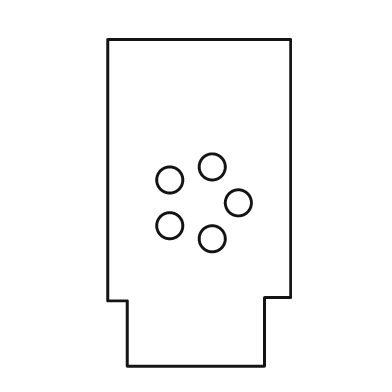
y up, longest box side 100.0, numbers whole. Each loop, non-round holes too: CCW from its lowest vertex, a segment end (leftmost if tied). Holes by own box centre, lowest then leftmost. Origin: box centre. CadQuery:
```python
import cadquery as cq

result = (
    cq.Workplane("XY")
    .moveTo(-22.0, -50.0)
    .lineTo(20.0, -50.0)
    .lineTo(20.0, -29.0)
    .lineTo(28.0, -29.0)
    .lineTo(28.0, 50.0)
    .lineTo(-28.0, 50.0)
    .lineTo(-28.0, -30.0)
    .lineTo(-22.0, -30.0)
    .close()
    .moveTo(4.0, -11.0)
    .circle(4.0)
    .moveTo(-9.0, -7.0)
    .circle(4.0)
    .moveTo(12.0, 0.0)
    .circle(4.0)
    .moveTo(-9.0, 7.0)
    .circle(4.0)
    .moveTo(4.0, 11.0)
    .circle(4.0)
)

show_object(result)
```